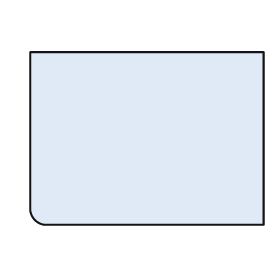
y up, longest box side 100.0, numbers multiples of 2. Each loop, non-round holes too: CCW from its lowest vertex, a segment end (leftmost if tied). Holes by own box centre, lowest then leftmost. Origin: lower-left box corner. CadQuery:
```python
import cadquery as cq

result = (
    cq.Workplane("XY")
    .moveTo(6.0, 0.0)
    .lineTo(100.0, 0.0)
    .lineTo(100.0, 74.0)
    .lineTo(0.0, 74.0)
    .lineTo(0.0, 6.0)
    .threePointArc((2.0, 2.0), (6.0, 0.0))
    .close()
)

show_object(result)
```